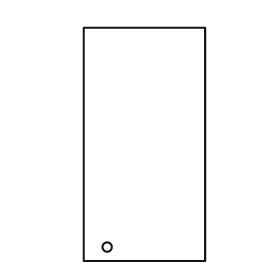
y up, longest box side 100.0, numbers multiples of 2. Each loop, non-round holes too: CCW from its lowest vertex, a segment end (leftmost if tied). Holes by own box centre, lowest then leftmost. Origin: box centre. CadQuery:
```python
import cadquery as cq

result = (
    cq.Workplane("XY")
    .moveTo(-26.0, -50.0)
    .lineTo(26.0, -50.0)
    .lineTo(26.0, 50.0)
    .lineTo(-26.0, 50.0)
    .close()
    .moveTo(-16.0, -44.0)
    .circle(2.0)
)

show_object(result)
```